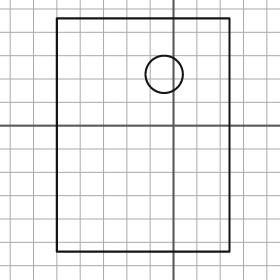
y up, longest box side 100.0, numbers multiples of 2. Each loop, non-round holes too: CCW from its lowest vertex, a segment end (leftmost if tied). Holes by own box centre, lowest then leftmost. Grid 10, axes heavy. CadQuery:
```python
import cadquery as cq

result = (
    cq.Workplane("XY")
    .moveTo(-50.0, -54.0)
    .lineTo(24.0, -54.0)
    .lineTo(24.0, 46.0)
    .lineTo(-50.0, 46.0)
    .close()
    .moveTo(-4.0, 22.0)
    .circle(8.0)
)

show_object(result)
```